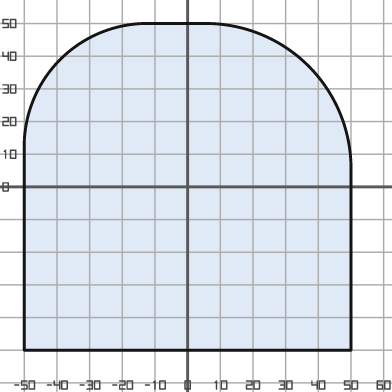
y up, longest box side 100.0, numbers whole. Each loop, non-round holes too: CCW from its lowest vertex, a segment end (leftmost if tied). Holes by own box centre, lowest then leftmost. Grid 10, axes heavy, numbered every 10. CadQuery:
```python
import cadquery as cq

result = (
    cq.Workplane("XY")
    .moveTo(-50.0, -50.0)
    .lineTo(50.0, -50.0)
    .lineTo(50.0, 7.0)
    .threePointArc((37.0, 37.0), (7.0, 50.0))
    .lineTo(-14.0, 50.0)
    .threePointArc((-39.0, 39.0), (-50.0, 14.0))
    .close()
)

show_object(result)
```